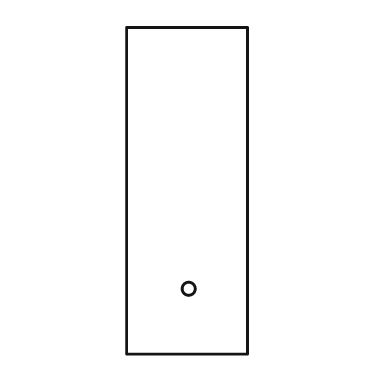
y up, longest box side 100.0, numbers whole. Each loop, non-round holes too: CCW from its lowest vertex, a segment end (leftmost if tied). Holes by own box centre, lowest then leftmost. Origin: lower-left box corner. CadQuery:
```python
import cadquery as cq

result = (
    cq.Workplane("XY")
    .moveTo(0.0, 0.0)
    .lineTo(37.0, 0.0)
    .lineTo(37.0, 100.0)
    .lineTo(0.0, 100.0)
    .close()
    .moveTo(19.0, 20.0)
    .circle(2.0)
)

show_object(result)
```